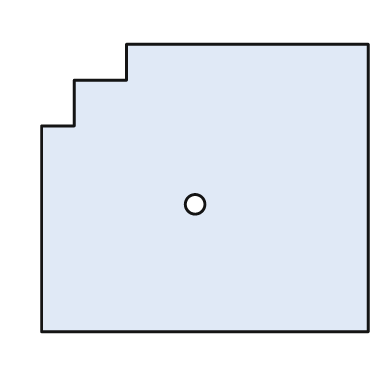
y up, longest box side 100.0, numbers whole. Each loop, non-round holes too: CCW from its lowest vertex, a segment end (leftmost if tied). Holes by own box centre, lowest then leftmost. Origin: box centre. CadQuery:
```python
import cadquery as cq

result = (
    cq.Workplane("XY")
    .moveTo(-50.0, -44.0)
    .lineTo(50.0, -44.0)
    .lineTo(50.0, 44.0)
    .lineTo(-24.0, 44.0)
    .lineTo(-24.0, 33.0)
    .lineTo(-40.0, 33.0)
    .lineTo(-40.0, 19.0)
    .lineTo(-50.0, 19.0)
    .close()
    .moveTo(-3.0, -5.0)
    .circle(3.0)
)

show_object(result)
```